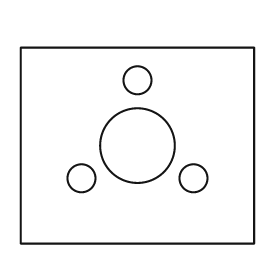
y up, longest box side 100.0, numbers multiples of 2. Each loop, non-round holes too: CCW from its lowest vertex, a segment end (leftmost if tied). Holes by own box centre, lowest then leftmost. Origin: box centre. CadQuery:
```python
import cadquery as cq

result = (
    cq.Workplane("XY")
    .moveTo(-50.0, -42.0)
    .lineTo(50.0, -42.0)
    .lineTo(50.0, 42.0)
    .lineTo(-50.0, 42.0)
    .close()
    .moveTo(-24.0, -14.0)
    .circle(6.0)
    .moveTo(24.0, -14.0)
    .circle(6.0)
    .moveTo(0.0, 0.0)
    .circle(16.0)
    .moveTo(0.0, 28.0)
    .circle(6.0)
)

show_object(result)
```